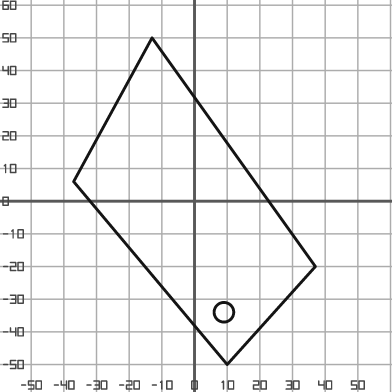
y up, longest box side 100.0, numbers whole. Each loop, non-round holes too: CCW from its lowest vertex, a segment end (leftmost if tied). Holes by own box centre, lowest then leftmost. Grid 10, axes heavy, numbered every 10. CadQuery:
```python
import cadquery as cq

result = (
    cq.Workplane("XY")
    .moveTo(10.0, -50.0)
    .lineTo(37.0, -20.0)
    .lineTo(-13.0, 50.0)
    .lineTo(-37.0, 6.0)
    .close()
    .moveTo(9.0, -34.0)
    .circle(3.0)
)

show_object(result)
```